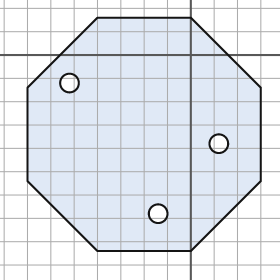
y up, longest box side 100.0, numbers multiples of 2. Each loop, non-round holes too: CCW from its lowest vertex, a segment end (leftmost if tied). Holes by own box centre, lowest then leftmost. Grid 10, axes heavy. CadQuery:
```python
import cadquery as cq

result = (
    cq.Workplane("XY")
    .moveTo(-40.0, -84.0)
    .lineTo(0.0, -84.0)
    .lineTo(30.0, -54.0)
    .lineTo(30.0, -14.0)
    .lineTo(0.0, 16.0)
    .lineTo(-40.0, 16.0)
    .lineTo(-70.0, -14.0)
    .lineTo(-70.0, -54.0)
    .close()
    .moveTo(-14.0, -68.0)
    .circle(4.0)
    .moveTo(12.0, -38.0)
    .circle(4.0)
    .moveTo(-52.0, -12.0)
    .circle(4.0)
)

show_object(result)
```